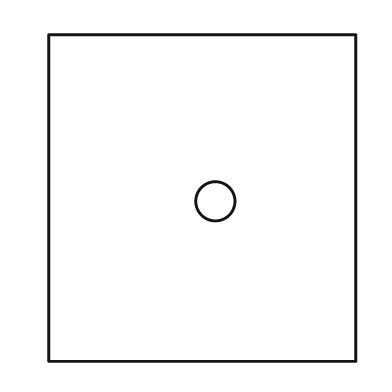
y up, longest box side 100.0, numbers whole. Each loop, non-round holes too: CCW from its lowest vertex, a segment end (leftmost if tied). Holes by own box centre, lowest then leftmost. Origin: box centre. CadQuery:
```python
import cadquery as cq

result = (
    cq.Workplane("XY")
    .moveTo(-47.0, -50.0)
    .lineTo(47.0, -50.0)
    .lineTo(47.0, 50.0)
    .lineTo(-47.0, 50.0)
    .close()
    .moveTo(4.0, -1.0)
    .circle(6.0)
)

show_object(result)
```